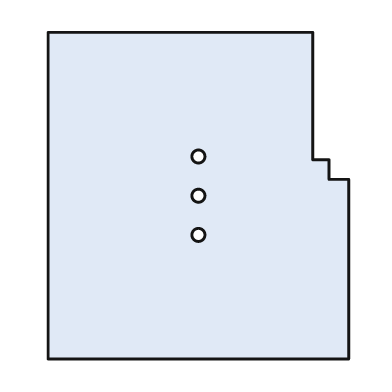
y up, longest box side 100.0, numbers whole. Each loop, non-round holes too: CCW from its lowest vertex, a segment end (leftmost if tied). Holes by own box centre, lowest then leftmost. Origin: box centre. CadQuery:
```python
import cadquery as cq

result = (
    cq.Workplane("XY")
    .moveTo(-46.0, -50.0)
    .lineTo(46.0, -50.0)
    .lineTo(46.0, 5.0)
    .lineTo(40.0, 5.0)
    .lineTo(40.0, 11.0)
    .lineTo(35.0, 11.0)
    .lineTo(35.0, 50.0)
    .lineTo(-46.0, 50.0)
    .close()
    .moveTo(0.0, -12.0)
    .circle(2.0)
    .moveTo(0.0, 0.0)
    .circle(2.0)
    .moveTo(0.0, 12.0)
    .circle(2.0)
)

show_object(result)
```